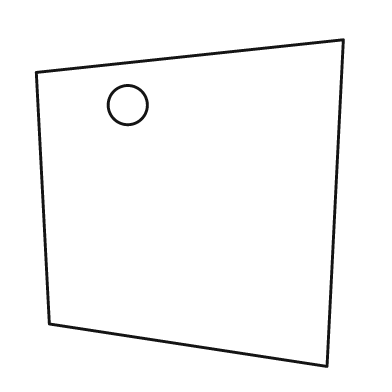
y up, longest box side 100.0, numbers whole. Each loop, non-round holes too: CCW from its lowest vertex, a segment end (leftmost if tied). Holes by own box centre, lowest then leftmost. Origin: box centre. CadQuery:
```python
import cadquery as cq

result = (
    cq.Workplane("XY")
    .moveTo(42.0, -50.0)
    .lineTo(47.0, 50.0)
    .lineTo(-47.0, 40.0)
    .lineTo(-43.0, -37.0)
    .close()
    .moveTo(-19.0, 30.0)
    .circle(6.0)
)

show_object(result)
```